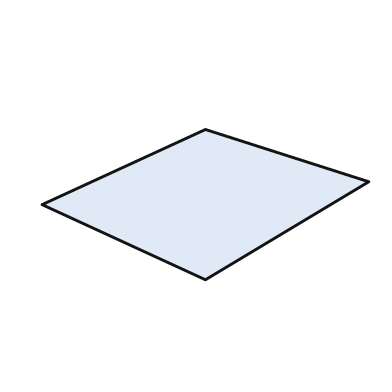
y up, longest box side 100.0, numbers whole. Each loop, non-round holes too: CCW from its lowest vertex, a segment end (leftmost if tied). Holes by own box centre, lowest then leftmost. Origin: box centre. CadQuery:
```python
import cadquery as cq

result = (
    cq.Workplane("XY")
    .moveTo(0.0, -23.0)
    .lineTo(50.0, 7.0)
    .lineTo(0.0, 23.0)
    .lineTo(-50.0, 0.0)
    .close()
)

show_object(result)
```